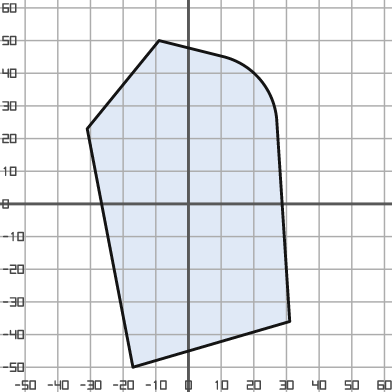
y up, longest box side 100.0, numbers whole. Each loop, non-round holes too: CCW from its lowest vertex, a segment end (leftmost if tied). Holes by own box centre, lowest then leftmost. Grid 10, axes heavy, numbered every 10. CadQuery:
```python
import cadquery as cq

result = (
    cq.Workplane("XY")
    .moveTo(-17.0, -50.0)
    .lineTo(31.0, -36.0)
    .lineTo(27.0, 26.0)
    .threePointArc((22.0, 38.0), (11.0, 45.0))
    .lineTo(-9.0, 50.0)
    .lineTo(-31.0, 23.0)
    .close()
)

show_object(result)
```